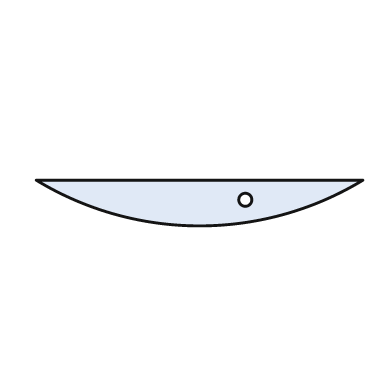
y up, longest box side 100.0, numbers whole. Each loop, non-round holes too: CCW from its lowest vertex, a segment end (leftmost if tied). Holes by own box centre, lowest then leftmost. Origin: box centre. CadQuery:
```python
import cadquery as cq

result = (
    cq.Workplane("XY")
    .moveTo(-50.0, 7.0)
    .threePointArc((0.0, -7.0), (50.0, 7.0))
    .close()
    .moveTo(14.0, 1.0)
    .circle(2.0)
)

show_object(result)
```